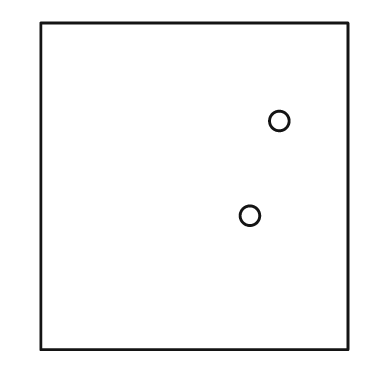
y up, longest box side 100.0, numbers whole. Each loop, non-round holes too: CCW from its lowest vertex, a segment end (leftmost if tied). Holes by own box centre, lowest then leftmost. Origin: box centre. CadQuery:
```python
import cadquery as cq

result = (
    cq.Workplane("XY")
    .moveTo(-47.0, -50.0)
    .lineTo(47.0, -50.0)
    .lineTo(47.0, 50.0)
    .lineTo(-47.0, 50.0)
    .close()
    .moveTo(17.0, -9.0)
    .circle(3.0)
    .moveTo(26.0, 20.0)
    .circle(3.0)
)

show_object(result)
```